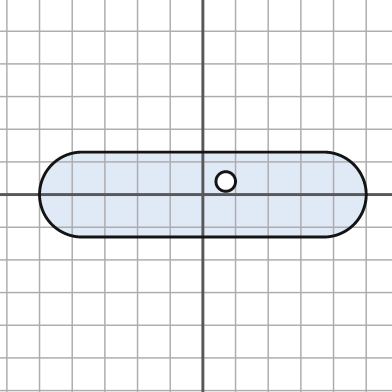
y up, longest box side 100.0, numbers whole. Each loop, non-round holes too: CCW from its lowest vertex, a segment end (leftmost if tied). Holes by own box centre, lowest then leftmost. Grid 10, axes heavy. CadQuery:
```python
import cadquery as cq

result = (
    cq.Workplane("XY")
    .moveTo(-37.0, -13.0)
    .lineTo(37.0, -13.0)
    .threePointArc((50.0, 0.0), (37.0, 13.0))
    .lineTo(-37.0, 13.0)
    .threePointArc((-50.0, 0.0), (-37.0, -13.0))
    .close()
    .moveTo(7.0, 4.0)
    .circle(3.0)
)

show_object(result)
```